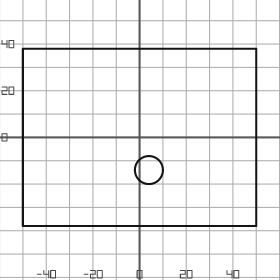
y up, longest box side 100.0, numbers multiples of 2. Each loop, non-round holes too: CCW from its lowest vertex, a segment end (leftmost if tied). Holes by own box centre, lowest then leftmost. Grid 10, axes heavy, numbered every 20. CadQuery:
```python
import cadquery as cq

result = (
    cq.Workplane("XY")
    .moveTo(-50.0, -38.0)
    .lineTo(50.0, -38.0)
    .lineTo(50.0, 38.0)
    .lineTo(-50.0, 38.0)
    .close()
    .moveTo(4.0, -14.0)
    .circle(6.0)
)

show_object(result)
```